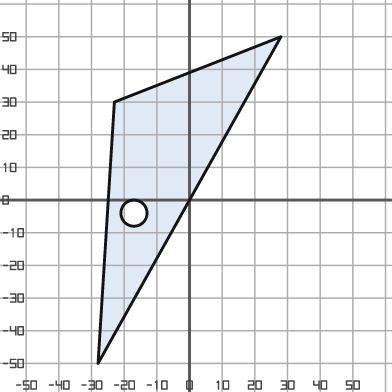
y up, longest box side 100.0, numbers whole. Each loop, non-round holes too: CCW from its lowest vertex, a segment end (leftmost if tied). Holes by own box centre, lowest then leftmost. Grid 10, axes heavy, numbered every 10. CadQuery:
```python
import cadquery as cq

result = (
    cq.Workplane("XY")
    .moveTo(-28.0, -50.0)
    .lineTo(28.0, 50.0)
    .lineTo(-23.0, 30.0)
    .close()
    .moveTo(-17.0, -4.0)
    .circle(4.0)
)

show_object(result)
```